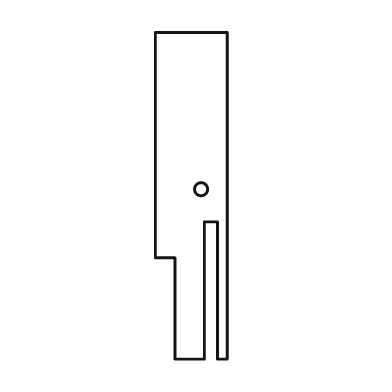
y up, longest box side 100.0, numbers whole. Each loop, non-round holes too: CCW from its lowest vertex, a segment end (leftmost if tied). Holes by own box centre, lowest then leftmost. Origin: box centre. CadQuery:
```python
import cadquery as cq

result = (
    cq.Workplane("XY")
    .moveTo(-5.0, -50.0)
    .lineTo(4.0, -50.0)
    .lineTo(4.0, -8.0)
    .lineTo(8.0, -8.0)
    .lineTo(8.0, -50.0)
    .lineTo(11.0, -50.0)
    .lineTo(11.0, 50.0)
    .lineTo(-11.0, 50.0)
    .lineTo(-11.0, -19.0)
    .lineTo(-5.0, -19.0)
    .close()
    .moveTo(3.0, 2.0)
    .circle(2.0)
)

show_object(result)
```